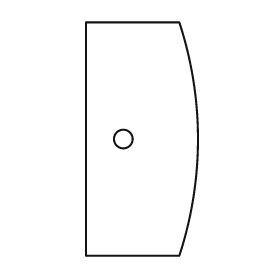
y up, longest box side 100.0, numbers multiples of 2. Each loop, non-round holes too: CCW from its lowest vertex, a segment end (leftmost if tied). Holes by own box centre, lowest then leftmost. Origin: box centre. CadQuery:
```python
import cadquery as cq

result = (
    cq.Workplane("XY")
    .moveTo(-24.0, -50.0)
    .lineTo(16.0, -50.0)
    .threePointArc((24.0, 0.0), (16.0, 50.0))
    .lineTo(-24.0, 50.0)
    .close()
    .moveTo(-8.0, 0.0)
    .circle(4.0)
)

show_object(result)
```